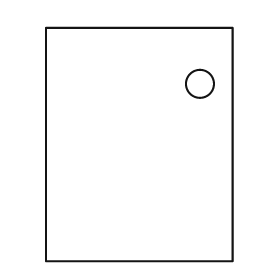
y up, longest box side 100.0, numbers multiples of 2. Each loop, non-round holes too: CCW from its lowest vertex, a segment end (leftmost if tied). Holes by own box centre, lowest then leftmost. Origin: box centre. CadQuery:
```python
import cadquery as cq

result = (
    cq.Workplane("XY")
    .moveTo(-40.0, -50.0)
    .lineTo(40.0, -50.0)
    .lineTo(40.0, 50.0)
    .lineTo(-40.0, 50.0)
    .close()
    .moveTo(26.0, 26.0)
    .circle(6.0)
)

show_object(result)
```